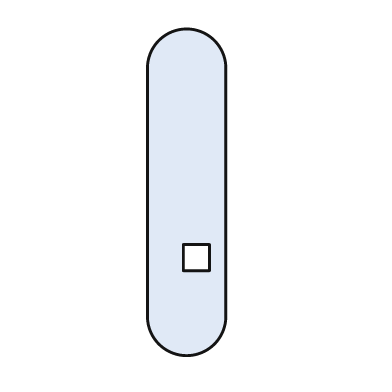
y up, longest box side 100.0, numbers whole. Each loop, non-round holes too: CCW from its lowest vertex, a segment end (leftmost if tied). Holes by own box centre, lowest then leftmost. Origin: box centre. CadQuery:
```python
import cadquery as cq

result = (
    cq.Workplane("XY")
    .moveTo(-12.0, -38.0)
    .threePointArc((0.0, -50.0), (12.0, -38.0))
    .lineTo(12.0, 38.0)
    .threePointArc((0.0, 50.0), (-12.0, 38.0))
    .close()
    .moveTo(-1.0, -24.0)
    .lineTo(7.0, -24.0)
    .lineTo(7.0, -16.0)
    .lineTo(-1.0, -16.0)
    .close()
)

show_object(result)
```